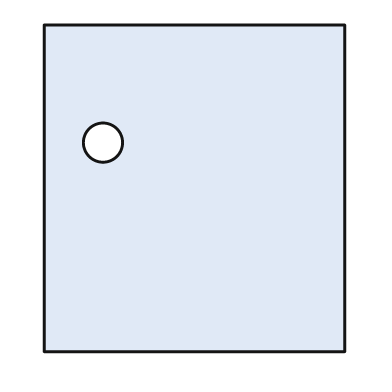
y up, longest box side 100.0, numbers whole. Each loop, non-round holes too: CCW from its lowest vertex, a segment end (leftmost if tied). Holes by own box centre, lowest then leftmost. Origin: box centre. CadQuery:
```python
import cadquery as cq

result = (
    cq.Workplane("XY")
    .moveTo(-46.0, -50.0)
    .lineTo(46.0, -50.0)
    .lineTo(46.0, 50.0)
    .lineTo(-46.0, 50.0)
    .close()
    .moveTo(-28.0, 14.0)
    .circle(6.0)
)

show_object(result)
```